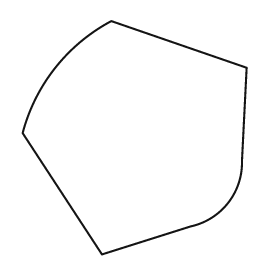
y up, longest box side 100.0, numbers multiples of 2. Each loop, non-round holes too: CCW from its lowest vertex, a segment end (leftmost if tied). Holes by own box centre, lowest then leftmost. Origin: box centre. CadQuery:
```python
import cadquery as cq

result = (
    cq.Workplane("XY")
    .moveTo(-14.0, -50.0)
    .lineTo(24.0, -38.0)
    .threePointArc((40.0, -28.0), (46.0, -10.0))
    .lineTo(48.0, 30.0)
    .lineTo(-10.0, 50.0)
    .threePointArc((-34.0, 30.0), (-48.0, 2.0))
    .close()
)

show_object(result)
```